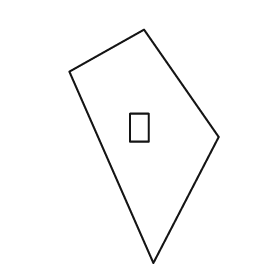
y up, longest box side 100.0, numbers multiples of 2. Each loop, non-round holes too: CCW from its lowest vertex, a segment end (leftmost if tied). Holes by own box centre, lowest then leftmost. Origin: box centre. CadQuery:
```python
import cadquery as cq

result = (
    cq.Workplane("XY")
    .moveTo(4.0, -50.0)
    .lineTo(32.0, 4.0)
    .lineTo(0.0, 50.0)
    .lineTo(-32.0, 32.0)
    .close()
    .moveTo(-6.0, 2.0)
    .lineTo(2.0, 2.0)
    .lineTo(2.0, 14.0)
    .lineTo(-6.0, 14.0)
    .close()
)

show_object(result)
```